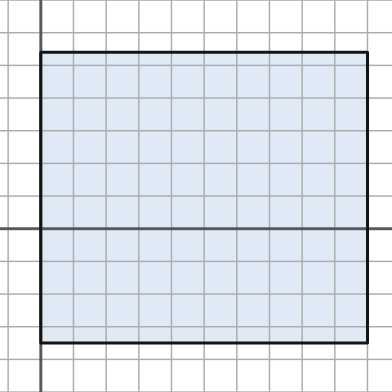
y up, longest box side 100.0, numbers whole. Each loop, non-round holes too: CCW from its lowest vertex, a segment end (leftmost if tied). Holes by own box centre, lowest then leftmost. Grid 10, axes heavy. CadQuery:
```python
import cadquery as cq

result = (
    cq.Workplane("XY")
    .moveTo(0.0, -35.0)
    .lineTo(100.0, -35.0)
    .lineTo(100.0, 54.0)
    .lineTo(0.0, 54.0)
    .close()
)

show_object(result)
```